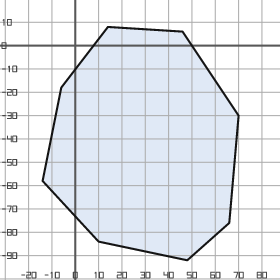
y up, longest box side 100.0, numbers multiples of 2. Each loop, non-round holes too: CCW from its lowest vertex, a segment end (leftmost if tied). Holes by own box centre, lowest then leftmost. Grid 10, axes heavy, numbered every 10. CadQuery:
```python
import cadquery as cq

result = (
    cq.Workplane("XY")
    .moveTo(48.0, -92.0)
    .lineTo(66.0, -76.0)
    .lineTo(70.0, -30.0)
    .lineTo(46.0, 6.0)
    .lineTo(14.0, 8.0)
    .lineTo(-6.0, -18.0)
    .lineTo(-14.0, -58.0)
    .lineTo(10.0, -84.0)
    .close()
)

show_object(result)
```